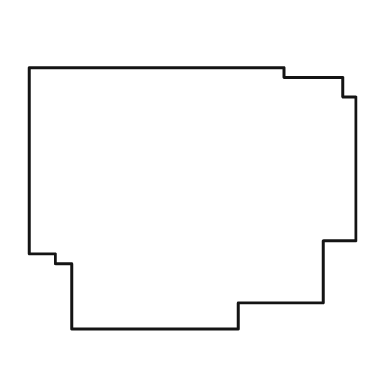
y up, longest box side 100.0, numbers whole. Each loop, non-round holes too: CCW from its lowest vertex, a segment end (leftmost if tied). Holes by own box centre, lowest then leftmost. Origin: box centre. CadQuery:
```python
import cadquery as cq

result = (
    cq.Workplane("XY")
    .moveTo(-37.0, -40.0)
    .lineTo(14.0, -40.0)
    .lineTo(14.0, -32.0)
    .lineTo(40.0, -32.0)
    .lineTo(40.0, -13.0)
    .lineTo(50.0, -13.0)
    .lineTo(50.0, 31.0)
    .lineTo(46.0, 31.0)
    .lineTo(46.0, 37.0)
    .lineTo(28.0, 37.0)
    .lineTo(28.0, 40.0)
    .lineTo(-50.0, 40.0)
    .lineTo(-50.0, -17.0)
    .lineTo(-42.0, -17.0)
    .lineTo(-42.0, -20.0)
    .lineTo(-37.0, -20.0)
    .close()
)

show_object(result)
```